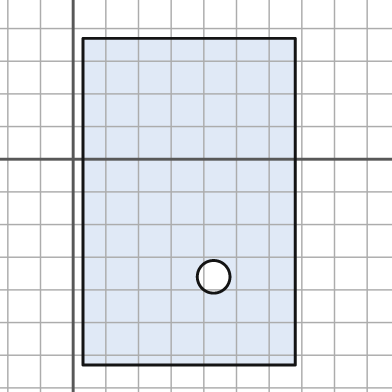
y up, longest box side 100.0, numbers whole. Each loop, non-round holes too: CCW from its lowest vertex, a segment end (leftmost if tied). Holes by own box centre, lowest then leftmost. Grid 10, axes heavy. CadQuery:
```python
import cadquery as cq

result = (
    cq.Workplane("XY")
    .moveTo(3.0, -63.0)
    .lineTo(68.0, -63.0)
    .lineTo(68.0, 37.0)
    .lineTo(3.0, 37.0)
    .close()
    .moveTo(43.0, -36.0)
    .circle(5.0)
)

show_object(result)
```